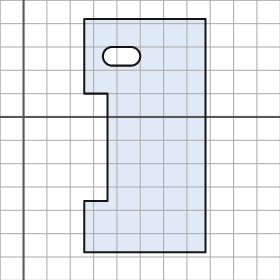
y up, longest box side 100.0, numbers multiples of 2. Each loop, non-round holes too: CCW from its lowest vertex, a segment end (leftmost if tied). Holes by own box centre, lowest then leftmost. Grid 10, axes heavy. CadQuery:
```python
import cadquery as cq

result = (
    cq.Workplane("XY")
    .moveTo(26.0, -58.0)
    .lineTo(78.0, -58.0)
    .lineTo(78.0, 42.0)
    .lineTo(26.0, 42.0)
    .lineTo(26.0, 10.0)
    .lineTo(36.0, 10.0)
    .lineTo(36.0, -36.0)
    .lineTo(26.0, -36.0)
    .close()
    .moveTo(38.0, 22.0)
    .lineTo(46.0, 22.0)
    .threePointArc((50.0, 26.0), (46.0, 30.0))
    .lineTo(38.0, 30.0)
    .threePointArc((34.0, 26.0), (38.0, 22.0))
    .close()
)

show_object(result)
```